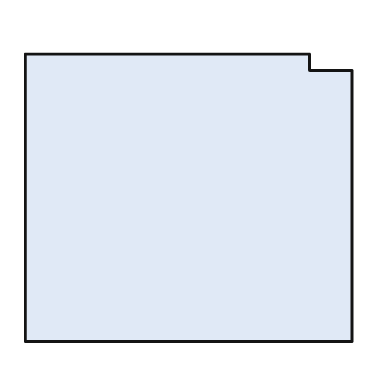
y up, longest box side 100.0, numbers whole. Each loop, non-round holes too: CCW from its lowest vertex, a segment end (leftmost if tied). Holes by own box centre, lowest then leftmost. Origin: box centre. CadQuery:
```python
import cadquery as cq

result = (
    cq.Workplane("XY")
    .moveTo(-50.0, -44.0)
    .lineTo(50.0, -44.0)
    .lineTo(50.0, 39.0)
    .lineTo(37.0, 39.0)
    .lineTo(37.0, 44.0)
    .lineTo(-50.0, 44.0)
    .close()
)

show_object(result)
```